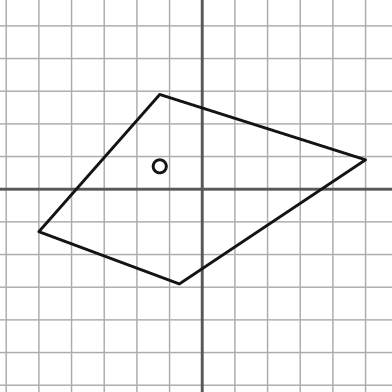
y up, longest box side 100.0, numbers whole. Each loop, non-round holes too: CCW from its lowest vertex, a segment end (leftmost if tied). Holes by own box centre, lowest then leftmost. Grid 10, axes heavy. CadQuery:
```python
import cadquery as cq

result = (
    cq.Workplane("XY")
    .moveTo(-7.0, -29.0)
    .lineTo(50.0, 9.0)
    .lineTo(-13.0, 29.0)
    .lineTo(-50.0, -13.0)
    .close()
    .moveTo(-13.0, 7.0)
    .circle(2.0)
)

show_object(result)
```